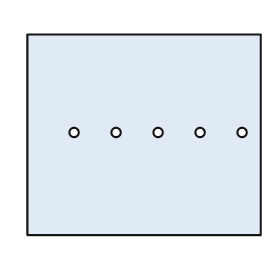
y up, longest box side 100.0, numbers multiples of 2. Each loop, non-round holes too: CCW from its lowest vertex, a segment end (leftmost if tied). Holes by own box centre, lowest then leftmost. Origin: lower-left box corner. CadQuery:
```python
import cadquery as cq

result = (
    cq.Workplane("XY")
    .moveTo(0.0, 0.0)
    .lineTo(100.0, 0.0)
    .lineTo(100.0, 86.0)
    .lineTo(0.0, 86.0)
    .close()
    .moveTo(20.0, 44.0)
    .circle(2.0)
    .moveTo(38.0, 44.0)
    .circle(2.0)
    .moveTo(56.0, 44.0)
    .circle(2.0)
    .moveTo(74.0, 44.0)
    .circle(2.0)
    .moveTo(92.0, 44.0)
    .circle(2.0)
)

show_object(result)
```